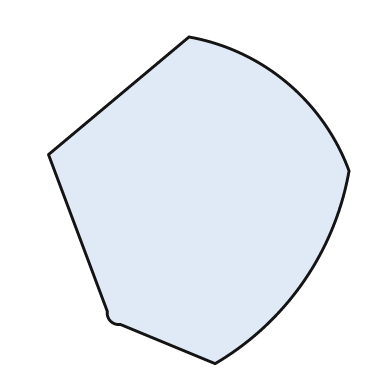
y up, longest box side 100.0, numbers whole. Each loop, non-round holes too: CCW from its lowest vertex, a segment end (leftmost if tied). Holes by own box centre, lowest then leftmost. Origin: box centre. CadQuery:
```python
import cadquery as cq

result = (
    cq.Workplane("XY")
    .moveTo(5.0, -50.0)
    .threePointArc((32.0, -25.0), (46.0, 9.0))
    .threePointArc((27.0, 36.0), (-3.0, 50.0))
    .lineTo(-46.0, 14.0)
    .lineTo(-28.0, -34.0)
    .threePointArc((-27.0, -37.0), (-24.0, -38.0))
    .close()
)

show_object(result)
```